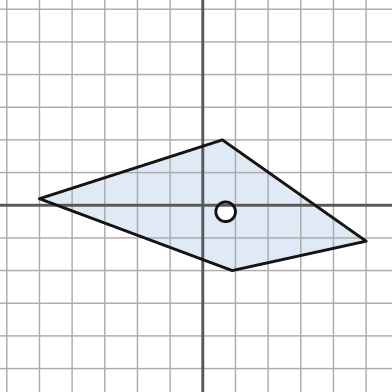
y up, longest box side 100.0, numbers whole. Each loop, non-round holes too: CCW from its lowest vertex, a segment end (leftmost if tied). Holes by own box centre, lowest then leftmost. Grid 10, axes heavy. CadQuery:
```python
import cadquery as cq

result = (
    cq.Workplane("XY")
    .moveTo(9.0, -20.0)
    .lineTo(50.0, -11.0)
    .lineTo(6.0, 20.0)
    .lineTo(-50.0, 2.0)
    .close()
    .moveTo(7.0, -2.0)
    .circle(3.0)
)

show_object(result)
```